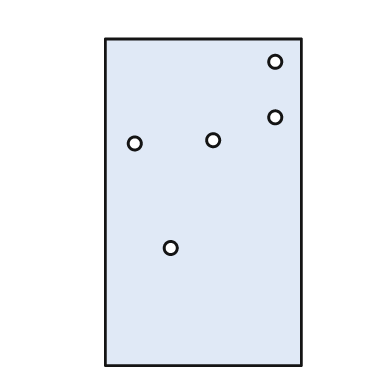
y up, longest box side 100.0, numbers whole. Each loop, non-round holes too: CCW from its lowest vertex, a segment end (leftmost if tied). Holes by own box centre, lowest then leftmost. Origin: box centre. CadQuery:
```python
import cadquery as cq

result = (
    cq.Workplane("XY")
    .moveTo(-30.0, -50.0)
    .lineTo(30.0, -50.0)
    .lineTo(30.0, 50.0)
    .lineTo(-30.0, 50.0)
    .close()
    .moveTo(-10.0, -14.0)
    .circle(2.0)
    .moveTo(-21.0, 18.0)
    .circle(2.0)
    .moveTo(3.0, 19.0)
    .circle(2.0)
    .moveTo(22.0, 26.0)
    .circle(2.0)
    .moveTo(22.0, 43.0)
    .circle(2.0)
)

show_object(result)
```